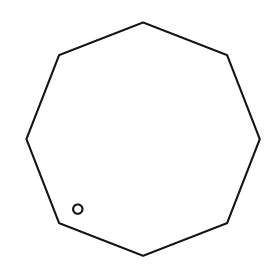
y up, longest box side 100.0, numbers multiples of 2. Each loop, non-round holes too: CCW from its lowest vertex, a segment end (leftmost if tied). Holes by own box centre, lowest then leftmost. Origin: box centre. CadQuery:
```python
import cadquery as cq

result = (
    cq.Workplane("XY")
    .moveTo(0.0, -50.0)
    .lineTo(36.0, -36.0)
    .lineTo(50.0, 0.0)
    .lineTo(36.0, 36.0)
    .lineTo(0.0, 50.0)
    .lineTo(-36.0, 36.0)
    .lineTo(-50.0, 0.0)
    .lineTo(-36.0, -36.0)
    .close()
    .moveTo(-28.0, -30.0)
    .circle(2.0)
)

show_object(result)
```